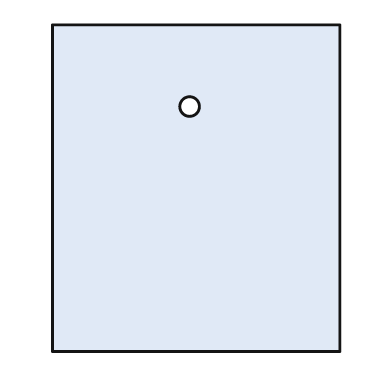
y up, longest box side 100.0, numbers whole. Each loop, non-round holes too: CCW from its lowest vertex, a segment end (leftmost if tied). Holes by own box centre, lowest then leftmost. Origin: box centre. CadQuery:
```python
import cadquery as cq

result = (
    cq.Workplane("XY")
    .moveTo(-44.0, -50.0)
    .lineTo(44.0, -50.0)
    .lineTo(44.0, 50.0)
    .lineTo(-44.0, 50.0)
    .close()
    .moveTo(-2.0, 25.0)
    .circle(3.0)
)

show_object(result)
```